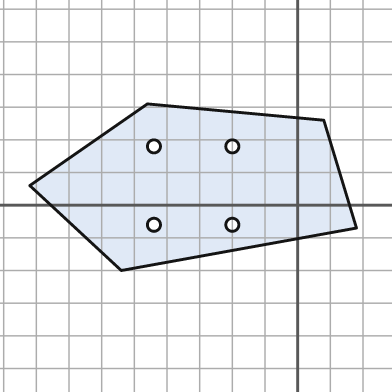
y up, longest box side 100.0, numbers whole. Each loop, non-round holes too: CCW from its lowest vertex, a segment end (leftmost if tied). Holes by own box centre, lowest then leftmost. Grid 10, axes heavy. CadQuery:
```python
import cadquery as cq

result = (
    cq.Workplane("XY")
    .moveTo(-54.0, -20.0)
    .lineTo(18.0, -7.0)
    .lineTo(8.0, 26.0)
    .lineTo(-46.0, 31.0)
    .lineTo(-82.0, 6.0)
    .close()
    .moveTo(-44.0, -6.0)
    .circle(2.0)
    .moveTo(-20.0, -6.0)
    .circle(2.0)
    .moveTo(-44.0, 18.0)
    .circle(2.0)
    .moveTo(-20.0, 18.0)
    .circle(2.0)
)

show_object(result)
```